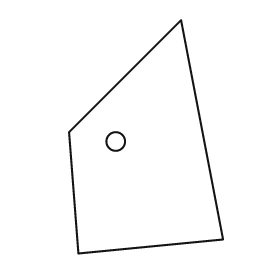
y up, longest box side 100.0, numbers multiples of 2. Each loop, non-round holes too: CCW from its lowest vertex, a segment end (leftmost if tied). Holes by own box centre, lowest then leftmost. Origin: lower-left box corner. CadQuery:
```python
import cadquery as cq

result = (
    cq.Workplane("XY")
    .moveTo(4.0, 0.0)
    .lineTo(66.0, 6.0)
    .lineTo(48.0, 100.0)
    .lineTo(0.0, 52.0)
    .close()
    .moveTo(20.0, 48.0)
    .circle(4.0)
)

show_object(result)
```